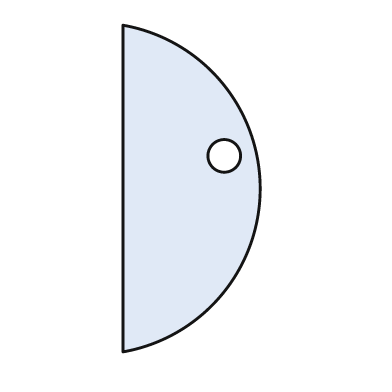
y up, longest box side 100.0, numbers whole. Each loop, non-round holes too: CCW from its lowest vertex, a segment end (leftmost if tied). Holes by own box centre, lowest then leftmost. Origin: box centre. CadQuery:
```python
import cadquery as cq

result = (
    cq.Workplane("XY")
    .moveTo(-21.0, -50.0)
    .threePointArc((21.0, 0.0), (-21.0, 50.0))
    .close()
    .moveTo(10.0, 10.0)
    .circle(5.0)
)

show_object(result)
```